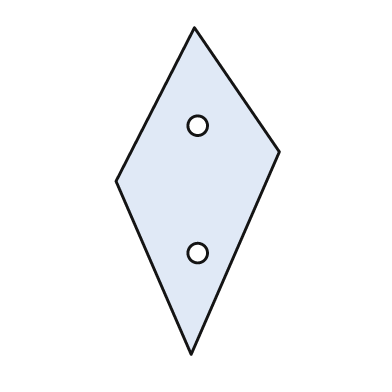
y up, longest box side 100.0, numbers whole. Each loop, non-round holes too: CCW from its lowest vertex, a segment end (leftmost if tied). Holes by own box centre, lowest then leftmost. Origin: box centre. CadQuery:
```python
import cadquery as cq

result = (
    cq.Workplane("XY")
    .moveTo(-2.0, -50.0)
    .lineTo(25.0, 12.0)
    .lineTo(-1.0, 50.0)
    .lineTo(-25.0, 3.0)
    .close()
    .moveTo(0.0, -19.0)
    .circle(3.0)
    .moveTo(0.0, 20.0)
    .circle(3.0)
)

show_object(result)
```